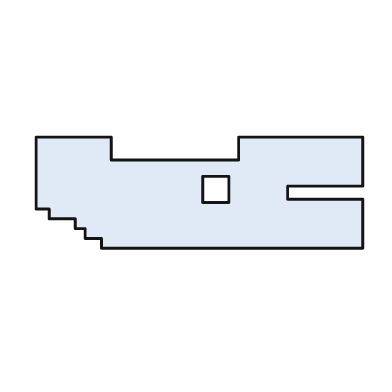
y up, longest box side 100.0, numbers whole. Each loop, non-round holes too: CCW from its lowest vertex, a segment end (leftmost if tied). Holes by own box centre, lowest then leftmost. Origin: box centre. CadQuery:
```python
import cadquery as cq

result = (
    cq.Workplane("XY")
    .moveTo(-30.0, -17.0)
    .lineTo(50.0, -17.0)
    .lineTo(50.0, -2.0)
    .lineTo(27.0, -2.0)
    .lineTo(27.0, 2.0)
    .lineTo(50.0, 2.0)
    .lineTo(50.0, 17.0)
    .lineTo(12.0, 17.0)
    .lineTo(12.0, 10.0)
    .lineTo(-27.0, 10.0)
    .lineTo(-27.0, 17.0)
    .lineTo(-50.0, 17.0)
    .lineTo(-50.0, -5.0)
    .lineTo(-46.0, -5.0)
    .lineTo(-46.0, -8.0)
    .lineTo(-38.0, -8.0)
    .lineTo(-38.0, -11.0)
    .lineTo(-35.0, -11.0)
    .lineTo(-35.0, -14.0)
    .lineTo(-30.0, -14.0)
    .close()
    .moveTo(1.0, -3.0)
    .lineTo(9.0, -3.0)
    .lineTo(9.0, 5.0)
    .lineTo(1.0, 5.0)
    .close()
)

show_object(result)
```